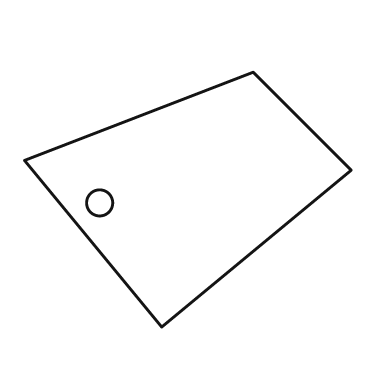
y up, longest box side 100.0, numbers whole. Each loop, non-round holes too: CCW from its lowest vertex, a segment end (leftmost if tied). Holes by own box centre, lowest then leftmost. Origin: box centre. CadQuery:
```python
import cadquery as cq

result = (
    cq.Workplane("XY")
    .moveTo(-8.0, -39.0)
    .lineTo(50.0, 9.0)
    .lineTo(20.0, 39.0)
    .lineTo(-50.0, 12.0)
    .close()
    .moveTo(-27.0, -1.0)
    .circle(4.0)
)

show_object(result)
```